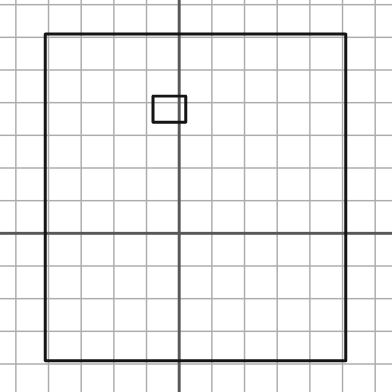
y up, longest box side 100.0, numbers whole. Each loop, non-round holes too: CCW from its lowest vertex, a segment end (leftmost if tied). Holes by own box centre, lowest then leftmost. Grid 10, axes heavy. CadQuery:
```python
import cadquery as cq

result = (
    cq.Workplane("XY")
    .moveTo(-41.0, -39.0)
    .lineTo(51.0, -39.0)
    .lineTo(51.0, 61.0)
    .lineTo(-41.0, 61.0)
    .close()
    .moveTo(-8.0, 34.0)
    .lineTo(2.0, 34.0)
    .lineTo(2.0, 42.0)
    .lineTo(-8.0, 42.0)
    .close()
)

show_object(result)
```